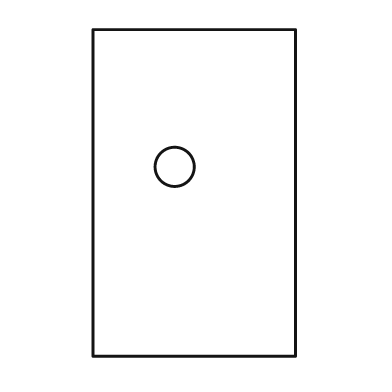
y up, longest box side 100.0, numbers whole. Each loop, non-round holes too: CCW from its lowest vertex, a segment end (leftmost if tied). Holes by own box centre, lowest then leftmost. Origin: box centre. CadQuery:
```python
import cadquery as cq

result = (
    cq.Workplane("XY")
    .moveTo(-31.0, -50.0)
    .lineTo(31.0, -50.0)
    .lineTo(31.0, 50.0)
    .lineTo(-31.0, 50.0)
    .close()
    .moveTo(-6.0, 8.0)
    .circle(6.0)
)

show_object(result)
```